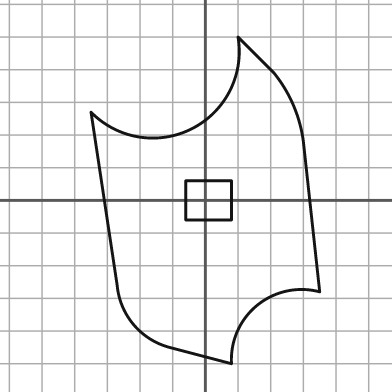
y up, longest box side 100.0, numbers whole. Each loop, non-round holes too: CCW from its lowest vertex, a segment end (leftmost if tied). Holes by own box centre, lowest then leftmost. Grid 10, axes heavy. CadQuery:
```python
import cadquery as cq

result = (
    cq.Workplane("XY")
    .moveTo(8.0, -50.0)
    .threePointArc((16.0, -32.0), (35.0, -28.0))
    .lineTo(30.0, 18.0)
    .threePointArc((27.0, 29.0), (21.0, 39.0))
    .lineTo(10.0, 50.0)
    .threePointArc((-4.0, 22.0), (-35.0, 27.0))
    .lineTo(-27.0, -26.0)
    .threePointArc((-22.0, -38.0), (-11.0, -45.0))
    .close()
    .moveTo(-6.0, -6.0)
    .lineTo(8.0, -6.0)
    .lineTo(8.0, 6.0)
    .lineTo(-6.0, 6.0)
    .close()
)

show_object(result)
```